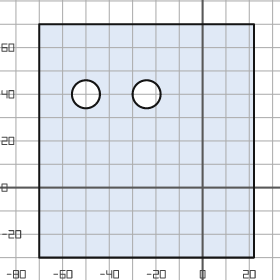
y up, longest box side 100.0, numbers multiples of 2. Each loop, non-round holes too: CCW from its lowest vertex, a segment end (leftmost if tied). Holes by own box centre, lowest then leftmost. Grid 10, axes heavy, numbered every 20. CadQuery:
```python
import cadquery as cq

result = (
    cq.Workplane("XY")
    .moveTo(-70.0, -30.0)
    .lineTo(22.0, -30.0)
    .lineTo(22.0, 70.0)
    .lineTo(-70.0, 70.0)
    .close()
    .moveTo(-50.0, 40.0)
    .circle(6.0)
    .moveTo(-24.0, 40.0)
    .circle(6.0)
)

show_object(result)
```